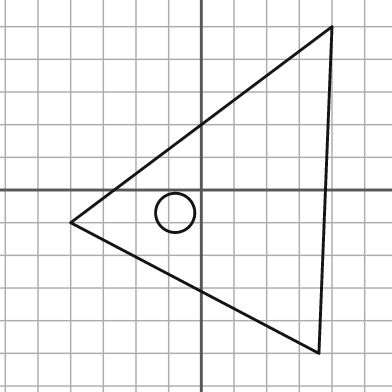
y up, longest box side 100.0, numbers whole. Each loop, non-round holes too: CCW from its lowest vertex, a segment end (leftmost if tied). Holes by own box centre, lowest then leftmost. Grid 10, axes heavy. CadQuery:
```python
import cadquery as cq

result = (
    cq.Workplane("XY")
    .moveTo(36.0, -50.0)
    .lineTo(40.0, 50.0)
    .lineTo(-40.0, -10.0)
    .close()
    .moveTo(-8.0, -7.0)
    .circle(6.0)
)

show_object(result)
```